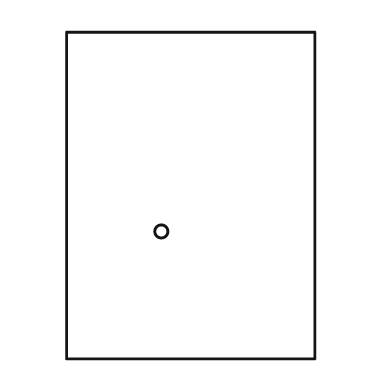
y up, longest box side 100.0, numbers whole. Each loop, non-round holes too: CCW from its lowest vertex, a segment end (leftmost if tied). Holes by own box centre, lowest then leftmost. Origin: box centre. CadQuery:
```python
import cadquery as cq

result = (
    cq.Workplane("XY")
    .moveTo(-38.0, -50.0)
    .lineTo(38.0, -50.0)
    .lineTo(38.0, 50.0)
    .lineTo(-38.0, 50.0)
    .close()
    .moveTo(-9.0, -11.0)
    .circle(2.0)
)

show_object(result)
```